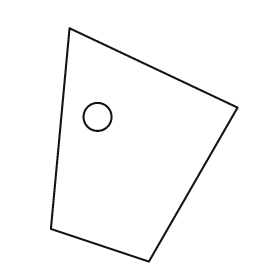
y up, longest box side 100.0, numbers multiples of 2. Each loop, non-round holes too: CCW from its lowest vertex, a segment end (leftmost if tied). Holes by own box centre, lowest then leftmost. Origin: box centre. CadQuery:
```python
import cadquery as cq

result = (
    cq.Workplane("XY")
    .moveTo(2.0, -50.0)
    .lineTo(40.0, 16.0)
    .lineTo(-32.0, 50.0)
    .lineTo(-40.0, -36.0)
    .close()
    .moveTo(-20.0, 12.0)
    .circle(6.0)
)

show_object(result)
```